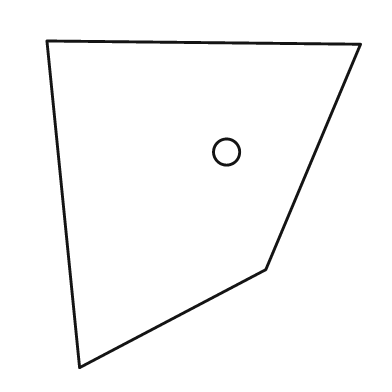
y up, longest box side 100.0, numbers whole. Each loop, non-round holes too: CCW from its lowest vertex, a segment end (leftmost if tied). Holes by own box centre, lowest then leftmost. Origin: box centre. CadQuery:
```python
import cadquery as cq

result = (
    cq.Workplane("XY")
    .moveTo(-38.0, -50.0)
    .lineTo(19.0, -20.0)
    .lineTo(48.0, 49.0)
    .lineTo(-48.0, 50.0)
    .close()
    .moveTo(7.0, 16.0)
    .circle(4.0)
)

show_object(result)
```